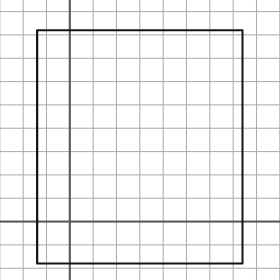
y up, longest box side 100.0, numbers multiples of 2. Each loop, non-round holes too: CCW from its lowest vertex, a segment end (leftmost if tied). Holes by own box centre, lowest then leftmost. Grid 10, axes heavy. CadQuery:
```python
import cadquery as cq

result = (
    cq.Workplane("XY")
    .moveTo(-14.0, -18.0)
    .lineTo(74.0, -18.0)
    .lineTo(74.0, 82.0)
    .lineTo(-14.0, 82.0)
    .close()
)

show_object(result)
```